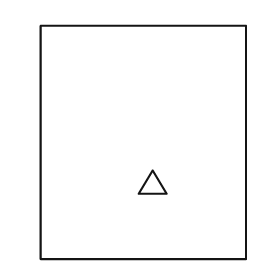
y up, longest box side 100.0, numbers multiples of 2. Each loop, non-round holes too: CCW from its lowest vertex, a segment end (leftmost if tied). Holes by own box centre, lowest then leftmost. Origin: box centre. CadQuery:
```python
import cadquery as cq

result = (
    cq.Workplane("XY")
    .moveTo(-44.0, -50.0)
    .lineTo(44.0, -50.0)
    .lineTo(44.0, 50.0)
    .lineTo(-44.0, 50.0)
    .close()
    .moveTo(-2.0, -22.0)
    .lineTo(10.0, -22.0)
    .lineTo(4.0, -12.0)
    .close()
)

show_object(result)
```